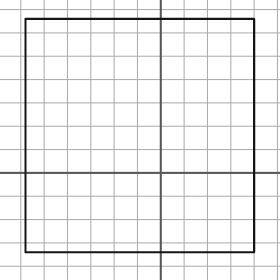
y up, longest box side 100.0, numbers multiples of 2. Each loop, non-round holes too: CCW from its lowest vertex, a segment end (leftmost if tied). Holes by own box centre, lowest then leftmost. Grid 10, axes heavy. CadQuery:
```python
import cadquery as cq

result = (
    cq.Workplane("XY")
    .moveTo(-58.0, -34.0)
    .lineTo(40.0, -34.0)
    .lineTo(40.0, 66.0)
    .lineTo(-58.0, 66.0)
    .close()
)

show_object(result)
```